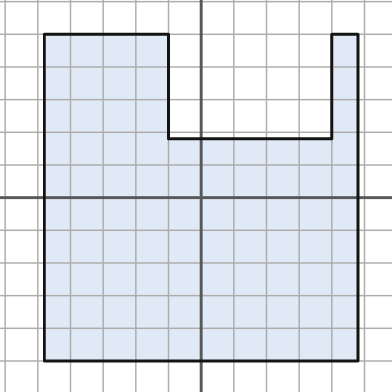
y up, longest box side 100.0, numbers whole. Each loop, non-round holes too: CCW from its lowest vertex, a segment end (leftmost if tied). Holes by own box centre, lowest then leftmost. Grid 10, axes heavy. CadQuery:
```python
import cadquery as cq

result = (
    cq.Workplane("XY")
    .moveTo(-48.0, -50.0)
    .lineTo(48.0, -50.0)
    .lineTo(48.0, 50.0)
    .lineTo(40.0, 50.0)
    .lineTo(40.0, 18.0)
    .lineTo(-10.0, 18.0)
    .lineTo(-10.0, 50.0)
    .lineTo(-48.0, 50.0)
    .close()
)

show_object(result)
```